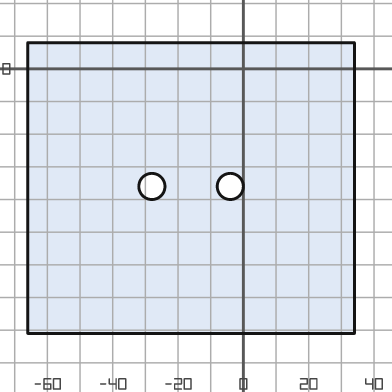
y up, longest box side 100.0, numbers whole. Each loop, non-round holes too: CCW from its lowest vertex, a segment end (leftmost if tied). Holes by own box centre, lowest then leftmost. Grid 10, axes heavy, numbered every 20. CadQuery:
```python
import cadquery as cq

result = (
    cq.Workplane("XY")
    .moveTo(-66.0, -81.0)
    .lineTo(34.0, -81.0)
    .lineTo(34.0, 8.0)
    .lineTo(-66.0, 8.0)
    .close()
    .moveTo(-28.0, -36.0)
    .circle(4.0)
    .moveTo(-4.0, -36.0)
    .circle(4.0)
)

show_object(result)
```